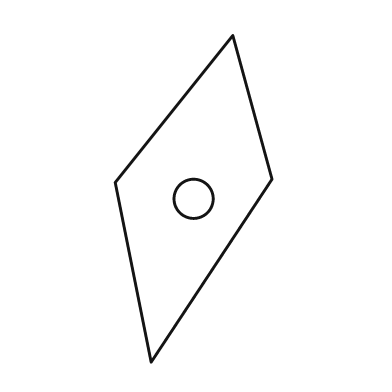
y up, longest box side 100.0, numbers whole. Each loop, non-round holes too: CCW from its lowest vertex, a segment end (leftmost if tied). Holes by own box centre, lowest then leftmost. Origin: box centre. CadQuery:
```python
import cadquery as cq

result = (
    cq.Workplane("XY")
    .moveTo(-13.0, -50.0)
    .lineTo(24.0, 6.0)
    .lineTo(12.0, 50.0)
    .lineTo(-24.0, 5.0)
    .close()
    .moveTo(0.0, 0.0)
    .circle(6.0)
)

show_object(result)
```